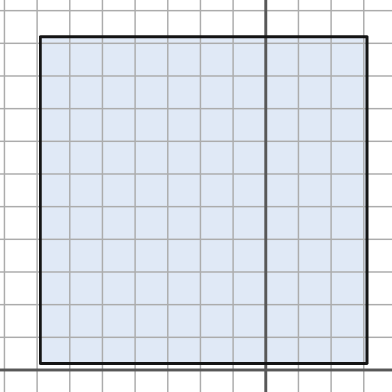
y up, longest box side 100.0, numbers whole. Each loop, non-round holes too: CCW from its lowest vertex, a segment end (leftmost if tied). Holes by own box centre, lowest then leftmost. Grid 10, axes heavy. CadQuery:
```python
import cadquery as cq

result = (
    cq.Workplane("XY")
    .moveTo(-69.0, 2.0)
    .lineTo(31.0, 2.0)
    .lineTo(31.0, 102.0)
    .lineTo(-69.0, 102.0)
    .close()
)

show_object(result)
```